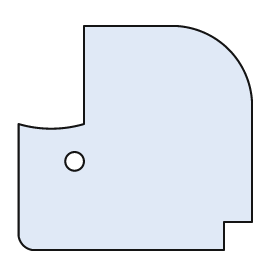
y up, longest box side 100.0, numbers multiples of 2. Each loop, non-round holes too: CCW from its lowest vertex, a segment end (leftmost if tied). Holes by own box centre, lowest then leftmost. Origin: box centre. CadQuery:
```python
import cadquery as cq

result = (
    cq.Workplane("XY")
    .moveTo(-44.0, -48.0)
    .lineTo(38.0, -48.0)
    .lineTo(38.0, -36.0)
    .lineTo(50.0, -36.0)
    .lineTo(50.0, 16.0)
    .threePointArc((40.0, 38.0), (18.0, 48.0))
    .lineTo(-22.0, 48.0)
    .lineTo(-22.0, 6.0)
    .threePointArc((-36.0, 4.0), (-50.0, 6.0))
    .lineTo(-50.0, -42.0)
    .threePointArc((-48.0, -46.0), (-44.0, -48.0))
    .close()
    .moveTo(-26.0, -10.0)
    .circle(4.0)
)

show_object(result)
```